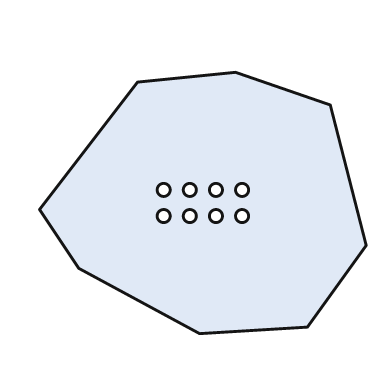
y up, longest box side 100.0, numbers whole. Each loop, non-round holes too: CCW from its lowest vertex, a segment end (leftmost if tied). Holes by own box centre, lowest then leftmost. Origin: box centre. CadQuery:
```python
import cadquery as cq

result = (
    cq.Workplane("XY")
    .moveTo(-1.0, -40.0)
    .lineTo(32.0, -38.0)
    .lineTo(50.0, -13.0)
    .lineTo(39.0, 30.0)
    .lineTo(10.0, 40.0)
    .lineTo(-20.0, 37.0)
    .lineTo(-50.0, -2.0)
    .lineTo(-38.0, -20.0)
    .close()
    .moveTo(-12.0, -4.0)
    .circle(2.0)
    .moveTo(-4.0, -4.0)
    .circle(2.0)
    .moveTo(4.0, -4.0)
    .circle(2.0)
    .moveTo(12.0, -4.0)
    .circle(2.0)
    .moveTo(-12.0, 4.0)
    .circle(2.0)
    .moveTo(-4.0, 4.0)
    .circle(2.0)
    .moveTo(4.0, 4.0)
    .circle(2.0)
    .moveTo(12.0, 4.0)
    .circle(2.0)
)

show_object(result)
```